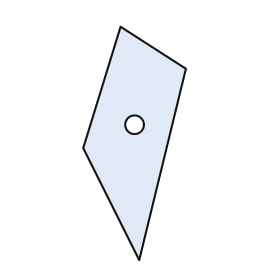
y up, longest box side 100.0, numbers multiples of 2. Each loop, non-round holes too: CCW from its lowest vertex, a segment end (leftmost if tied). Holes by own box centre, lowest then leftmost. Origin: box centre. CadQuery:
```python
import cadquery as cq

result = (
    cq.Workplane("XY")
    .moveTo(2.0, -50.0)
    .lineTo(22.0, 32.0)
    .lineTo(-6.0, 50.0)
    .lineTo(-22.0, -2.0)
    .close()
    .moveTo(0.0, 8.0)
    .circle(4.0)
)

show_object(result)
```